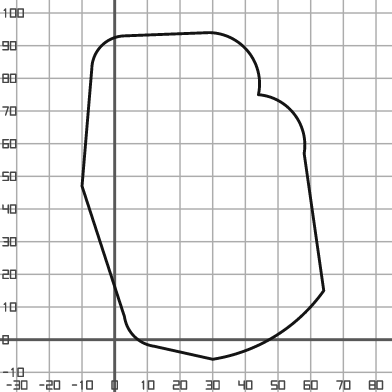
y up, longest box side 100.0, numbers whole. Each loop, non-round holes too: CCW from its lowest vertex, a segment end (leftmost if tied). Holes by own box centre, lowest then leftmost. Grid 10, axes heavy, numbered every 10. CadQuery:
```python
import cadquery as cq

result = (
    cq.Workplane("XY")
    .moveTo(30.0, -6.0)
    .threePointArc((49.0, 1.0), (64.0, 15.0))
    .lineTo(58.0, 57.0)
    .threePointArc((55.0, 69.0), (44.0, 75.0))
    .threePointArc((41.0, 88.0), (29.0, 94.0))
    .lineTo(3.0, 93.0)
    .threePointArc((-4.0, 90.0), (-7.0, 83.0))
    .lineTo(-10.0, 47.0)
    .lineTo(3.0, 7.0)
    .threePointArc((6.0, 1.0), (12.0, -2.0))
    .close()
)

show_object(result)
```